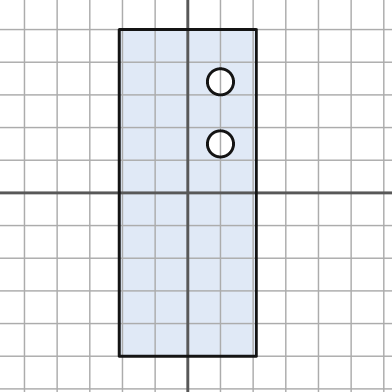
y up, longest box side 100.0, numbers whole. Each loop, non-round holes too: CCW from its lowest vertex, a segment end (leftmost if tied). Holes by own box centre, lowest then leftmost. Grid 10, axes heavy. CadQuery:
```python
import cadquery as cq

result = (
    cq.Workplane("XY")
    .moveTo(-21.0, -50.0)
    .lineTo(21.0, -50.0)
    .lineTo(21.0, 50.0)
    .lineTo(-21.0, 50.0)
    .close()
    .moveTo(10.0, 15.0)
    .circle(4.0)
    .moveTo(10.0, 34.0)
    .circle(4.0)
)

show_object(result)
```